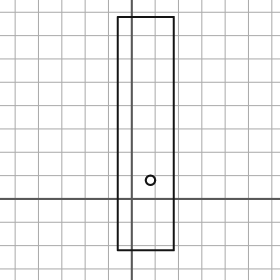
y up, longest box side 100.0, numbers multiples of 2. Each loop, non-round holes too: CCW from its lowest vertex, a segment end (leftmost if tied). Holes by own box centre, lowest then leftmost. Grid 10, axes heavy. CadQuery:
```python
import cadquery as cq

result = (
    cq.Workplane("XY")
    .moveTo(-6.0, -22.0)
    .lineTo(18.0, -22.0)
    .lineTo(18.0, 78.0)
    .lineTo(-6.0, 78.0)
    .close()
    .moveTo(8.0, 8.0)
    .circle(2.0)
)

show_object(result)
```